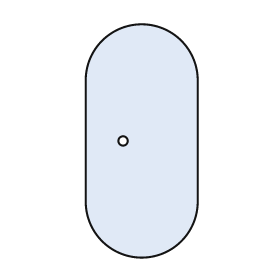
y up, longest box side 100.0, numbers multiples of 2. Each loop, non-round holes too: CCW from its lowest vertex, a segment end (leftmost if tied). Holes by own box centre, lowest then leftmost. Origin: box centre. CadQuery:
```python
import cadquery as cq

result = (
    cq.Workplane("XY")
    .moveTo(-24.0, -26.0)
    .threePointArc((0.0, -50.0), (24.0, -26.0))
    .lineTo(24.0, 26.0)
    .threePointArc((0.0, 50.0), (-24.0, 26.0))
    .close()
    .moveTo(-8.0, 0.0)
    .circle(2.0)
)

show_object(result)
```